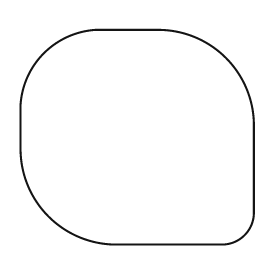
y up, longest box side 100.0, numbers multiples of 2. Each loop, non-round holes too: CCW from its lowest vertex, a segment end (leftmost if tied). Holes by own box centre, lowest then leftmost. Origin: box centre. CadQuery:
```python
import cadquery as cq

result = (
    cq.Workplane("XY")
    .moveTo(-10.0, -46.0)
    .lineTo(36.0, -46.0)
    .threePointArc((46.0, -42.0), (50.0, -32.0))
    .lineTo(50.0, 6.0)
    .threePointArc((38.0, 34.0), (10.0, 46.0))
    .lineTo(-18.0, 46.0)
    .threePointArc((-40.0, 36.0), (-50.0, 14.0))
    .lineTo(-50.0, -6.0)
    .threePointArc((-38.0, -34.0), (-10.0, -46.0))
    .close()
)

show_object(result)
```